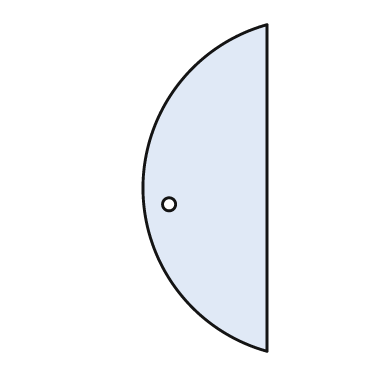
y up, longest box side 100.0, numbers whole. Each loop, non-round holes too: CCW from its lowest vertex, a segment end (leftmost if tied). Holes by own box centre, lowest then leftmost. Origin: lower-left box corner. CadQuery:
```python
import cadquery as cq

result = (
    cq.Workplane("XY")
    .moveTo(38.0, 0.0)
    .lineTo(38.0, 100.0)
    .threePointArc((0.0, 50.0), (38.0, 0.0))
    .close()
    .moveTo(8.0, 45.0)
    .circle(2.0)
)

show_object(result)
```